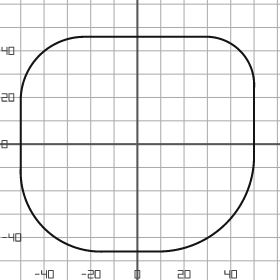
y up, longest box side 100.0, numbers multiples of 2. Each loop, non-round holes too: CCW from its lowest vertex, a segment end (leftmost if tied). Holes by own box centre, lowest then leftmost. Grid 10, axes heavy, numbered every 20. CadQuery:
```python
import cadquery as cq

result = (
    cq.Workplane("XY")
    .moveTo(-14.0, -46.0)
    .lineTo(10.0, -46.0)
    .threePointArc((38.0, -34.0), (50.0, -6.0))
    .lineTo(50.0, 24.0)
    .threePointArc((44.0, 40.0), (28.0, 46.0))
    .lineTo(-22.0, 46.0)
    .threePointArc((-42.0, 38.0), (-50.0, 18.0))
    .lineTo(-50.0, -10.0)
    .threePointArc((-40.0, -36.0), (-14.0, -46.0))
    .close()
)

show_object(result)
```